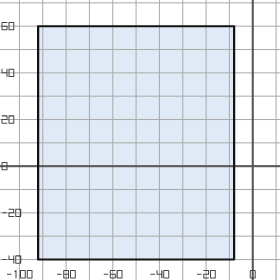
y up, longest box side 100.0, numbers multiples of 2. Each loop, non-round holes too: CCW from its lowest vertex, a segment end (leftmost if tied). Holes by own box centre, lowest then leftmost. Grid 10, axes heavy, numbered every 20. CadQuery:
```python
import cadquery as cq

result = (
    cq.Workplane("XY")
    .moveTo(-92.0, -40.0)
    .lineTo(-8.0, -40.0)
    .lineTo(-8.0, 60.0)
    .lineTo(-92.0, 60.0)
    .close()
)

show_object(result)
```